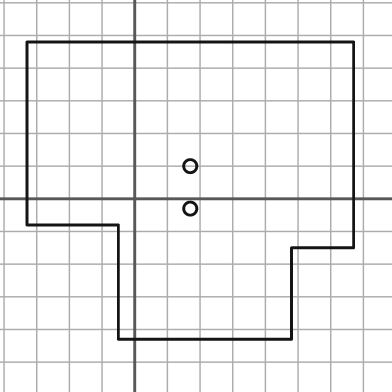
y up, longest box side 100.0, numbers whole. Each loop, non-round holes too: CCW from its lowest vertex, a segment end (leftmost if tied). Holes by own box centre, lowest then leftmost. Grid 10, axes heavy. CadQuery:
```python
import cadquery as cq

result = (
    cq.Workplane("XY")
    .moveTo(-5.0, -43.0)
    .lineTo(48.0, -43.0)
    .lineTo(48.0, -15.0)
    .lineTo(67.0, -15.0)
    .lineTo(67.0, 48.0)
    .lineTo(-33.0, 48.0)
    .lineTo(-33.0, -8.0)
    .lineTo(-5.0, -8.0)
    .close()
    .moveTo(17.0, -3.0)
    .circle(2.0)
    .moveTo(17.0, 10.0)
    .circle(2.0)
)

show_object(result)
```